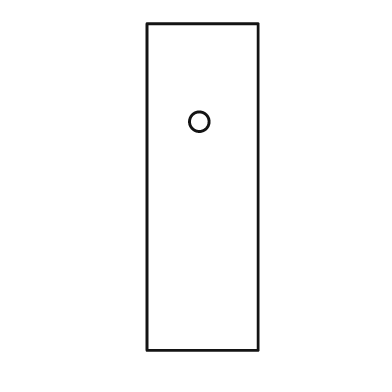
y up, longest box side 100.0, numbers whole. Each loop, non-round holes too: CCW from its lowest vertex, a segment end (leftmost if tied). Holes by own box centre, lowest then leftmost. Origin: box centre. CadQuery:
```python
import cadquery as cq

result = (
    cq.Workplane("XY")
    .moveTo(-17.0, -50.0)
    .lineTo(17.0, -50.0)
    .lineTo(17.0, 50.0)
    .lineTo(-17.0, 50.0)
    .close()
    .moveTo(-1.0, 20.0)
    .circle(3.0)
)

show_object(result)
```